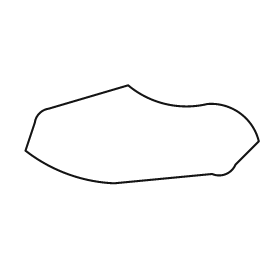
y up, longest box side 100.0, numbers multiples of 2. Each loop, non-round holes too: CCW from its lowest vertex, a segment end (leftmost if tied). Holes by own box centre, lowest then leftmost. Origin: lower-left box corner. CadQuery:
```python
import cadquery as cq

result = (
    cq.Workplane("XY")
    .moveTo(38.0, 0.0)
    .lineTo(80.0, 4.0)
    .threePointArc((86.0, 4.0), (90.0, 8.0))
    .lineTo(100.0, 18.0)
    .threePointArc((92.0, 30.0), (78.0, 34.0))
    .threePointArc((60.0, 34.0), (44.0, 42.0))
    .lineTo(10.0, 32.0)
    .threePointArc((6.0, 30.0), (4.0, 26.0))
    .lineTo(0.0, 14.0)
    .threePointArc((18.0, 4.0), (38.0, 0.0))
    .close()
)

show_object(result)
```